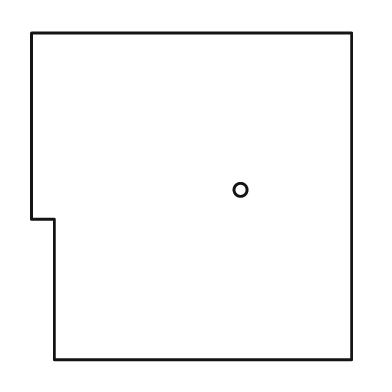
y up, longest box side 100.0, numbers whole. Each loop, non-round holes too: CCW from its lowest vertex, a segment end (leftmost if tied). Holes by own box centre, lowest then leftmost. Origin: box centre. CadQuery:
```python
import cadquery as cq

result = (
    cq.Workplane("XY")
    .moveTo(-42.0, -50.0)
    .lineTo(49.0, -50.0)
    .lineTo(49.0, 50.0)
    .lineTo(-49.0, 50.0)
    .lineTo(-49.0, -7.0)
    .lineTo(-42.0, -7.0)
    .close()
    .moveTo(15.0, 2.0)
    .circle(2.0)
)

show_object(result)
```